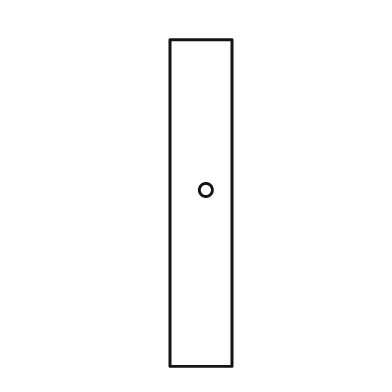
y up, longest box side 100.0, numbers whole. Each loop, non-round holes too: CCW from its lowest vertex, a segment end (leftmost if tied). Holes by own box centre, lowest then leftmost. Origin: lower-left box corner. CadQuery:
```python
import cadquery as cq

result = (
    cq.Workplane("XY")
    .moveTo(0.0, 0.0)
    .lineTo(19.0, 0.0)
    .lineTo(19.0, 100.0)
    .lineTo(0.0, 100.0)
    .close()
    .moveTo(11.0, 54.0)
    .circle(2.0)
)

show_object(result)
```